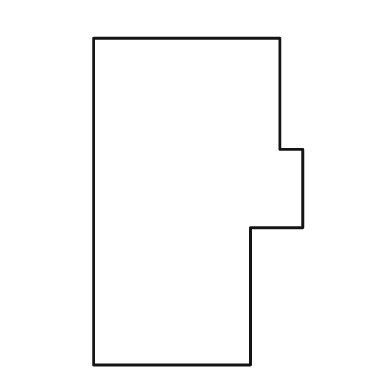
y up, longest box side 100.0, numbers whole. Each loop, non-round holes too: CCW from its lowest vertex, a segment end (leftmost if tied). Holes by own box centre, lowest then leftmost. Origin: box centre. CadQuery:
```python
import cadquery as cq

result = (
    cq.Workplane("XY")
    .moveTo(-32.0, -50.0)
    .lineTo(16.0, -50.0)
    .lineTo(16.0, -8.0)
    .lineTo(32.0, -8.0)
    .lineTo(32.0, 16.0)
    .lineTo(25.0, 16.0)
    .lineTo(25.0, 50.0)
    .lineTo(-32.0, 50.0)
    .close()
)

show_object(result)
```